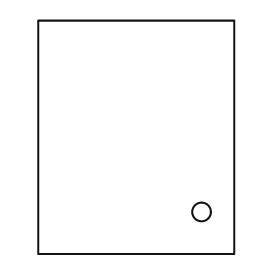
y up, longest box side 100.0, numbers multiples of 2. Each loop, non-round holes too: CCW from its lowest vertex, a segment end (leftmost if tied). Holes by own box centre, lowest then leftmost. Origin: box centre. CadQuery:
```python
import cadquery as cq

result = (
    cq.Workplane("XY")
    .moveTo(-42.0, -50.0)
    .lineTo(42.0, -50.0)
    .lineTo(42.0, 50.0)
    .lineTo(-42.0, 50.0)
    .close()
    .moveTo(28.0, -32.0)
    .circle(4.0)
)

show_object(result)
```